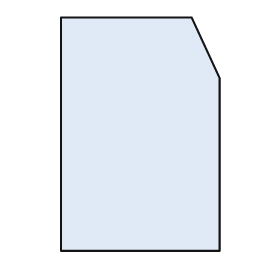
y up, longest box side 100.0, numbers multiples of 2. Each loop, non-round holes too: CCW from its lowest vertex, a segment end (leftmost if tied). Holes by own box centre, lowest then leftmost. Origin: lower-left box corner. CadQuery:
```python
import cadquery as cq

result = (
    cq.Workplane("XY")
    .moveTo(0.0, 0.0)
    .lineTo(68.0, 0.0)
    .lineTo(68.0, 74.0)
    .lineTo(56.0, 100.0)
    .lineTo(0.0, 100.0)
    .close()
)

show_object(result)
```